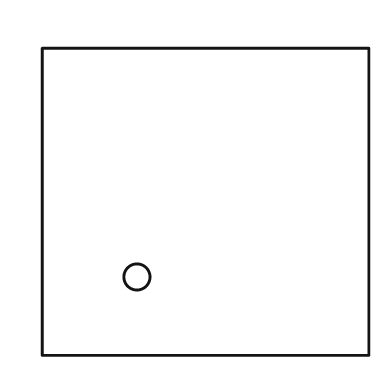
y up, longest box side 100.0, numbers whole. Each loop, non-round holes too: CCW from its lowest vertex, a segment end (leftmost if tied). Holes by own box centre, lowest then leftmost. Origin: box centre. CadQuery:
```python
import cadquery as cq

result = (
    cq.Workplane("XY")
    .moveTo(-50.0, -47.0)
    .lineTo(50.0, -47.0)
    .lineTo(50.0, 47.0)
    .lineTo(-50.0, 47.0)
    .close()
    .moveTo(-21.0, -23.0)
    .circle(4.0)
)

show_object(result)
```